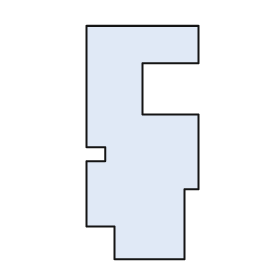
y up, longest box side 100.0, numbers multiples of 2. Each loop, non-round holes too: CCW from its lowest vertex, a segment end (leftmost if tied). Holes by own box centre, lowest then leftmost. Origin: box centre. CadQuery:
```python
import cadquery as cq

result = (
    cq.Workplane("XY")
    .moveTo(-12.0, -50.0)
    .lineTo(18.0, -50.0)
    .lineTo(18.0, -20.0)
    .lineTo(24.0, -20.0)
    .lineTo(24.0, 12.0)
    .lineTo(0.0, 12.0)
    .lineTo(0.0, 34.0)
    .lineTo(24.0, 34.0)
    .lineTo(24.0, 50.0)
    .lineTo(-24.0, 50.0)
    .lineTo(-24.0, -2.0)
    .lineTo(-16.0, -2.0)
    .lineTo(-16.0, -8.0)
    .lineTo(-24.0, -8.0)
    .lineTo(-24.0, -36.0)
    .lineTo(-12.0, -36.0)
    .close()
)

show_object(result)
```